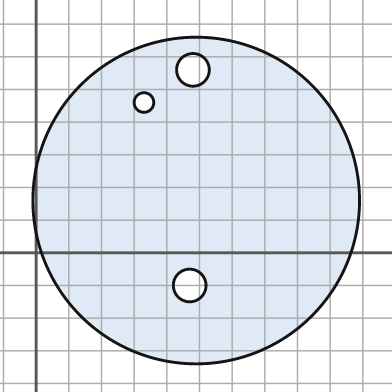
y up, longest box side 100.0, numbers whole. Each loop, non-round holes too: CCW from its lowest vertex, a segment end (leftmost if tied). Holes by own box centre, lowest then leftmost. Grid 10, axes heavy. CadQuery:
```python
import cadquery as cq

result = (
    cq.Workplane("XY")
    .moveTo(49.0, 16.0)
    .circle(50.0)
    .moveTo(47.0, -10.0)
    .circle(5.0)
    .moveTo(33.0, 46.0)
    .circle(3.0)
    .moveTo(48.0, 56.0)
    .circle(5.0)
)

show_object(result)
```